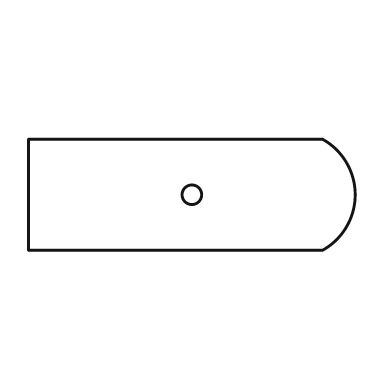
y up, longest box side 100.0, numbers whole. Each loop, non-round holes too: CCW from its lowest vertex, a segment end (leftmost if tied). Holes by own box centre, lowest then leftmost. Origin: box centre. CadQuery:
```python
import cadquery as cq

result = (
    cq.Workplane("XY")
    .moveTo(-50.0, -17.0)
    .lineTo(40.0, -17.0)
    .threePointArc((50.0, 0.0), (40.0, 17.0))
    .lineTo(-50.0, 17.0)
    .close()
    .moveTo(0.0, 0.0)
    .circle(3.0)
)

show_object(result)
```